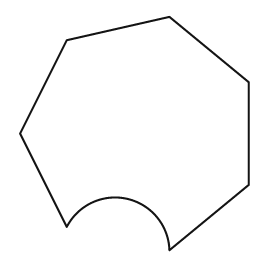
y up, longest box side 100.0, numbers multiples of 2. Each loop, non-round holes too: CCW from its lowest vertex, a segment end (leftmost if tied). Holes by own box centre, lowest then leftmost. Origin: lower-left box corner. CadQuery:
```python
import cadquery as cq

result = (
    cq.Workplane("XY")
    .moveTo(64.0, 0.0)
    .lineTo(98.0, 28.0)
    .lineTo(98.0, 72.0)
    .lineTo(64.0, 100.0)
    .lineTo(20.0, 90.0)
    .lineTo(0.0, 50.0)
    .lineTo(20.0, 10.0)
    .threePointArc((46.0, 22.0), (64.0, 0.0))
    .close()
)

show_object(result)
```